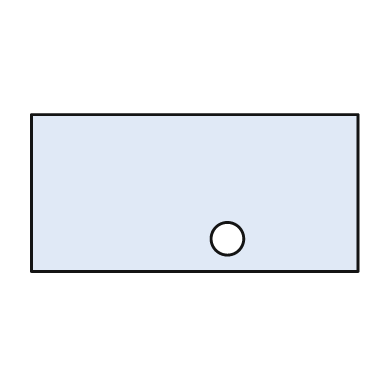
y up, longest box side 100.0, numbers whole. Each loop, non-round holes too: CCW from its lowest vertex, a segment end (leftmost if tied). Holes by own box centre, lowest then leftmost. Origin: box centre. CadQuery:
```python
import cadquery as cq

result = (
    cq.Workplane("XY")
    .moveTo(-50.0, -24.0)
    .lineTo(50.0, -24.0)
    .lineTo(50.0, 24.0)
    .lineTo(-50.0, 24.0)
    .close()
    .moveTo(10.0, -14.0)
    .circle(5.0)
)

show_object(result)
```